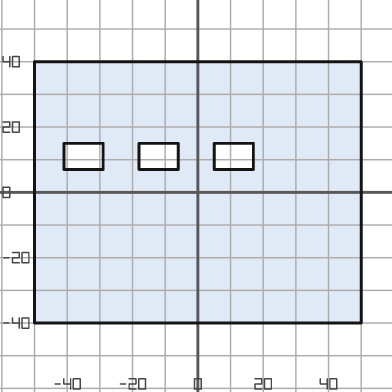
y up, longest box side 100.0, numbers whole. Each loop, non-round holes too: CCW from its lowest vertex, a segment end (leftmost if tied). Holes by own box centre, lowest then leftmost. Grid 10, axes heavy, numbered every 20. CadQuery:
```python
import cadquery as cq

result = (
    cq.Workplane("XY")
    .moveTo(-50.0, -40.0)
    .lineTo(50.0, -40.0)
    .lineTo(50.0, 40.0)
    .lineTo(-50.0, 40.0)
    .close()
    .moveTo(-41.0, 7.0)
    .lineTo(-29.0, 7.0)
    .lineTo(-29.0, 15.0)
    .lineTo(-41.0, 15.0)
    .close()
    .moveTo(-18.0, 7.0)
    .lineTo(-6.0, 7.0)
    .lineTo(-6.0, 15.0)
    .lineTo(-18.0, 15.0)
    .close()
    .moveTo(5.0, 7.0)
    .lineTo(17.0, 7.0)
    .lineTo(17.0, 15.0)
    .lineTo(5.0, 15.0)
    .close()
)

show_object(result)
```